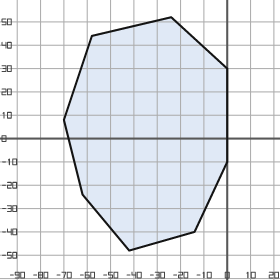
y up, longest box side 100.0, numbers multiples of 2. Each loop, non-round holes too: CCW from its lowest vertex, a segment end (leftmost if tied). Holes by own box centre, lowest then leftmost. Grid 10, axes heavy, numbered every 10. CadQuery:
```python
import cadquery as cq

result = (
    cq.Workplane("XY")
    .moveTo(-42.0, -48.0)
    .lineTo(-14.0, -40.0)
    .lineTo(0.0, -10.0)
    .lineTo(0.0, 30.0)
    .lineTo(-24.0, 52.0)
    .lineTo(-58.0, 44.0)
    .lineTo(-70.0, 8.0)
    .lineTo(-62.0, -24.0)
    .close()
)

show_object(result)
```